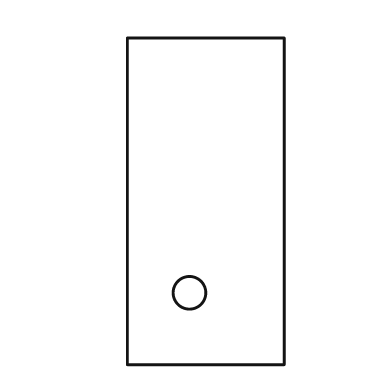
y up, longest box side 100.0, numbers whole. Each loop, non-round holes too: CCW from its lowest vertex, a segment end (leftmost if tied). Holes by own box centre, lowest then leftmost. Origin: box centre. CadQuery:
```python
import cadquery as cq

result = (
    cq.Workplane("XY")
    .moveTo(-24.0, -50.0)
    .lineTo(24.0, -50.0)
    .lineTo(24.0, 50.0)
    .lineTo(-24.0, 50.0)
    .close()
    .moveTo(-5.0, -28.0)
    .circle(5.0)
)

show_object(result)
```